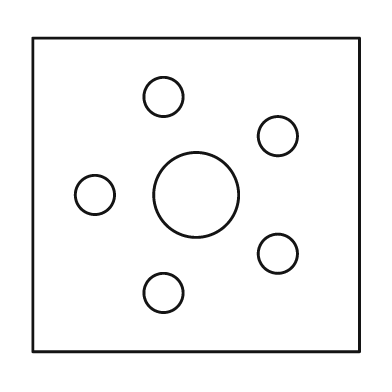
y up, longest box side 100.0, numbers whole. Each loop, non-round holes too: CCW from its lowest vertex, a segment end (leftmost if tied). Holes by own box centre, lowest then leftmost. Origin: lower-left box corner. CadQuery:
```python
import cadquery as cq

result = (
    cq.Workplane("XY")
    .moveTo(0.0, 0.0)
    .lineTo(100.0, 0.0)
    .lineTo(100.0, 96.0)
    .lineTo(0.0, 96.0)
    .close()
    .moveTo(40.0, 18.0)
    .circle(6.0)
    .moveTo(75.0, 30.0)
    .circle(6.0)
    .moveTo(19.0, 48.0)
    .circle(6.0)
    .moveTo(50.0, 48.0)
    .circle(13.0)
    .moveTo(75.0, 66.0)
    .circle(6.0)
    .moveTo(40.0, 78.0)
    .circle(6.0)
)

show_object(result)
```